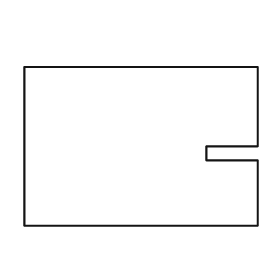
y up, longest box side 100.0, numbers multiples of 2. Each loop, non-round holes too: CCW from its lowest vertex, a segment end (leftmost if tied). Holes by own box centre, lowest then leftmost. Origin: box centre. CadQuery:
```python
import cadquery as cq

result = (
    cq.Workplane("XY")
    .moveTo(-50.0, -34.0)
    .lineTo(50.0, -34.0)
    .lineTo(50.0, -6.0)
    .lineTo(28.0, -6.0)
    .lineTo(28.0, 0.0)
    .lineTo(50.0, 0.0)
    .lineTo(50.0, 34.0)
    .lineTo(-50.0, 34.0)
    .close()
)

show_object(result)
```